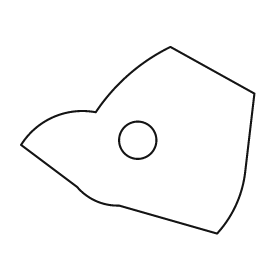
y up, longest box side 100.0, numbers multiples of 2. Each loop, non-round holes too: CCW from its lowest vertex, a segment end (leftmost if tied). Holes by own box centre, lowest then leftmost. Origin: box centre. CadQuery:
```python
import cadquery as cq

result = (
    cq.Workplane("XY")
    .moveTo(34.0, -40.0)
    .threePointArc((42.0, -28.0), (46.0, -14.0))
    .lineTo(50.0, 20.0)
    .lineTo(14.0, 40.0)
    .threePointArc((-4.0, 28.0), (-18.0, 12.0))
    .threePointArc((-36.0, 10.0), (-50.0, -2.0))
    .lineTo(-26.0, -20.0)
    .threePointArc((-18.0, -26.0), (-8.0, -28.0))
    .close()
    .moveTo(0.0, 0.0)
    .circle(8.0)
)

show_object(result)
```